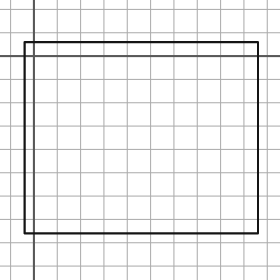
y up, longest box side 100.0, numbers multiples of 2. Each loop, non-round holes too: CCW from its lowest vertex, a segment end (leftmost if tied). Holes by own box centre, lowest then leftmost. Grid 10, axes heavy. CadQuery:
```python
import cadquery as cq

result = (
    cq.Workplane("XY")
    .moveTo(-4.0, -76.0)
    .lineTo(96.0, -76.0)
    .lineTo(96.0, 6.0)
    .lineTo(-4.0, 6.0)
    .close()
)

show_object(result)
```